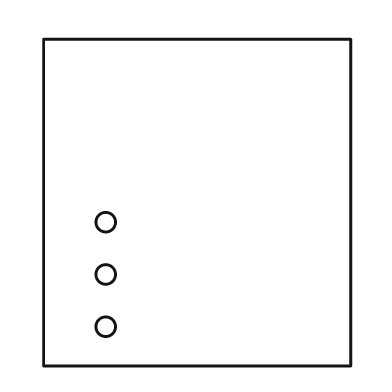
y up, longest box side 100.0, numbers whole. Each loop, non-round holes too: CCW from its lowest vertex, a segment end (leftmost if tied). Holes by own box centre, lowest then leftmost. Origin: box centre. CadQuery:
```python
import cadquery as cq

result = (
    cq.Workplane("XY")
    .moveTo(-47.0, -50.0)
    .lineTo(47.0, -50.0)
    .lineTo(47.0, 50.0)
    .lineTo(-47.0, 50.0)
    .close()
    .moveTo(-28.0, -38.0)
    .circle(3.0)
    .moveTo(-28.0, -22.0)
    .circle(3.0)
    .moveTo(-28.0, -6.0)
    .circle(3.0)
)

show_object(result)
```